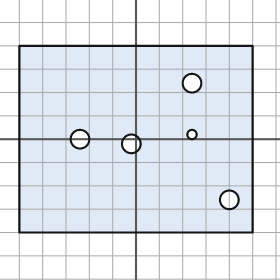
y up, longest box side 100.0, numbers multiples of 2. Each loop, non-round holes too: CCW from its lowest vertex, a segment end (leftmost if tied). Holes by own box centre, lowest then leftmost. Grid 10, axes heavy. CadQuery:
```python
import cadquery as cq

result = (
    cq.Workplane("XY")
    .moveTo(-50.0, -40.0)
    .lineTo(50.0, -40.0)
    .lineTo(50.0, 40.0)
    .lineTo(-50.0, 40.0)
    .close()
    .moveTo(40.0, -26.0)
    .circle(4.0)
    .moveTo(-2.0, -2.0)
    .circle(4.0)
    .moveTo(-24.0, 0.0)
    .circle(4.0)
    .moveTo(24.0, 2.0)
    .circle(2.0)
    .moveTo(24.0, 24.0)
    .circle(4.0)
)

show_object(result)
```